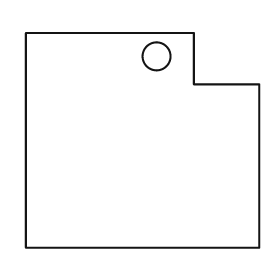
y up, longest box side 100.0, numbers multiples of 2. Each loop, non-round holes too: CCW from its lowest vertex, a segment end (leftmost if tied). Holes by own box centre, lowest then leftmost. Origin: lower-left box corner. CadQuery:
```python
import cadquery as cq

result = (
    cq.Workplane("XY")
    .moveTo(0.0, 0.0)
    .lineTo(100.0, 0.0)
    .lineTo(100.0, 70.0)
    .lineTo(72.0, 70.0)
    .lineTo(72.0, 92.0)
    .lineTo(0.0, 92.0)
    .close()
    .moveTo(56.0, 82.0)
    .circle(6.0)
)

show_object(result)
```